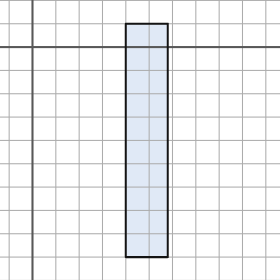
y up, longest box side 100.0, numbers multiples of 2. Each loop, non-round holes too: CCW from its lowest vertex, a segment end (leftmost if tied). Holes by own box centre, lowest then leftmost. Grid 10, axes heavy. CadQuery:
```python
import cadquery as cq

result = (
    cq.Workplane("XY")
    .moveTo(40.0, -90.0)
    .lineTo(58.0, -90.0)
    .lineTo(58.0, 10.0)
    .lineTo(40.0, 10.0)
    .close()
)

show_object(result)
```